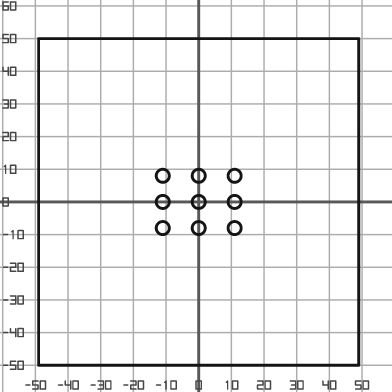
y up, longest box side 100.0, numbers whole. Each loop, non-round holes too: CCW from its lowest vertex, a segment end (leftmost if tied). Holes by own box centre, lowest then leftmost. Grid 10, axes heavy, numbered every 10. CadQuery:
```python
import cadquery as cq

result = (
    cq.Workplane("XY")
    .moveTo(-49.0, -50.0)
    .lineTo(49.0, -50.0)
    .lineTo(49.0, 50.0)
    .lineTo(-49.0, 50.0)
    .close()
    .moveTo(-11.0, -8.0)
    .circle(2.0)
    .moveTo(0.0, -8.0)
    .circle(2.0)
    .moveTo(11.0, -8.0)
    .circle(2.0)
    .moveTo(-11.0, 0.0)
    .circle(2.0)
    .moveTo(0.0, 0.0)
    .circle(2.0)
    .moveTo(11.0, 0.0)
    .circle(2.0)
    .moveTo(-11.0, 8.0)
    .circle(2.0)
    .moveTo(0.0, 8.0)
    .circle(2.0)
    .moveTo(11.0, 8.0)
    .circle(2.0)
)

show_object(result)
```